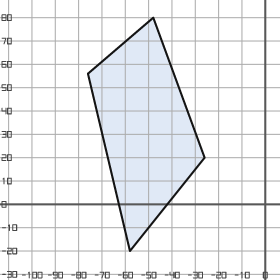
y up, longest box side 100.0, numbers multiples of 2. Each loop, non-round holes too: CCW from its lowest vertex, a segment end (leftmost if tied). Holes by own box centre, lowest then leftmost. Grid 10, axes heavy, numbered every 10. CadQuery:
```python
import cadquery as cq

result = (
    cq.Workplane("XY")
    .moveTo(-58.0, -20.0)
    .lineTo(-26.0, 20.0)
    .lineTo(-48.0, 80.0)
    .lineTo(-76.0, 56.0)
    .close()
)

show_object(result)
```